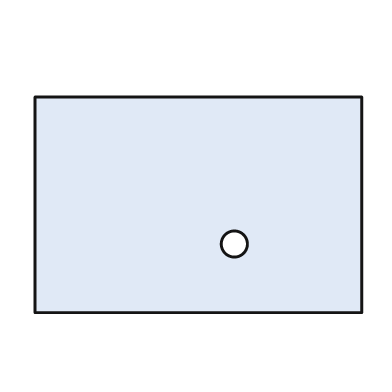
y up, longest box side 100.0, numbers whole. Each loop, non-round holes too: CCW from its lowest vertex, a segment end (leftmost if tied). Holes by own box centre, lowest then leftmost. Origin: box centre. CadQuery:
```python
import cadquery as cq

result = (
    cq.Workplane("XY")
    .moveTo(-50.0, -33.0)
    .lineTo(50.0, -33.0)
    .lineTo(50.0, 33.0)
    .lineTo(-50.0, 33.0)
    .close()
    .moveTo(11.0, -12.0)
    .circle(4.0)
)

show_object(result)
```